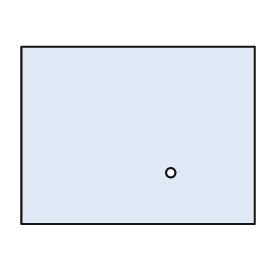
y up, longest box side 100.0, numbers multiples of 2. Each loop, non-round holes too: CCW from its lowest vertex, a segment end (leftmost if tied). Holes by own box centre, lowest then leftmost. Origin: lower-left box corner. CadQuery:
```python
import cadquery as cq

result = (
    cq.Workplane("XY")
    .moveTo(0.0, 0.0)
    .lineTo(100.0, 0.0)
    .lineTo(100.0, 76.0)
    .lineTo(0.0, 76.0)
    .close()
    .moveTo(64.0, 22.0)
    .circle(2.0)
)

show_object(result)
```